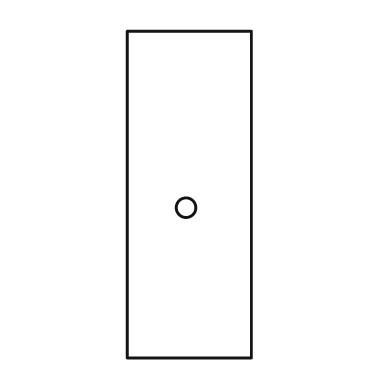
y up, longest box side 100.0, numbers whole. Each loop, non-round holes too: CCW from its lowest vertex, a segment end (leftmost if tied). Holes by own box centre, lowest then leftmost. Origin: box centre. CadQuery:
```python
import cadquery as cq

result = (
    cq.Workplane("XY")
    .moveTo(-19.0, -50.0)
    .lineTo(19.0, -50.0)
    .lineTo(19.0, 50.0)
    .lineTo(-19.0, 50.0)
    .close()
    .moveTo(-1.0, -4.0)
    .circle(3.0)
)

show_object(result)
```